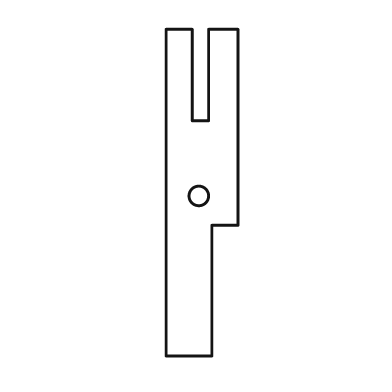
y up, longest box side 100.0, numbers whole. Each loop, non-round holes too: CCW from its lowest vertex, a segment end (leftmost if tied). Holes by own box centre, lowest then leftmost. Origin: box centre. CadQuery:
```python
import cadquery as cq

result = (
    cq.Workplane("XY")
    .moveTo(-11.0, -50.0)
    .lineTo(3.0, -50.0)
    .lineTo(3.0, -10.0)
    .lineTo(11.0, -10.0)
    .lineTo(11.0, 50.0)
    .lineTo(2.0, 50.0)
    .lineTo(2.0, 22.0)
    .lineTo(-3.0, 22.0)
    .lineTo(-3.0, 50.0)
    .lineTo(-11.0, 50.0)
    .close()
    .moveTo(-1.0, -1.0)
    .circle(3.0)
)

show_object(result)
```